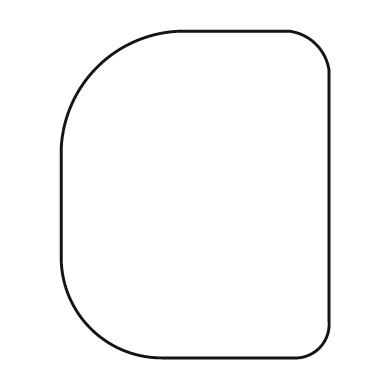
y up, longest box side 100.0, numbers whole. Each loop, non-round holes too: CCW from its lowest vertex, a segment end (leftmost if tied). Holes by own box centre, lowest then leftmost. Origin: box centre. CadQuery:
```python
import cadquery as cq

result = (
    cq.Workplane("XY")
    .moveTo(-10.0, -50.0)
    .lineTo(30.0, -50.0)
    .threePointArc((38.0, -47.0), (41.0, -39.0))
    .lineTo(41.0, 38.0)
    .threePointArc((37.0, 46.0), (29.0, 50.0))
    .lineTo(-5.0, 50.0)
    .threePointArc((-30.0, 39.0), (-41.0, 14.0))
    .lineTo(-41.0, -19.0)
    .threePointArc((-32.0, -41.0), (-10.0, -50.0))
    .close()
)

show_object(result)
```